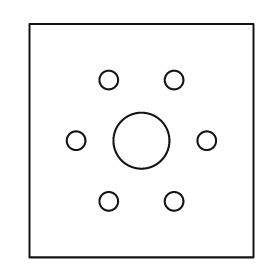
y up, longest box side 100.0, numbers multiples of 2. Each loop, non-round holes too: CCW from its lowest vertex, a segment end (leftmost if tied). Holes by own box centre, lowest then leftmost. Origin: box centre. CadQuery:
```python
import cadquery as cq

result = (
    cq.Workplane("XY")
    .moveTo(-48.0, -50.0)
    .lineTo(48.0, -50.0)
    .lineTo(48.0, 50.0)
    .lineTo(-48.0, 50.0)
    .close()
    .moveTo(-14.0, -26.0)
    .circle(4.0)
    .moveTo(14.0, -26.0)
    .circle(4.0)
    .moveTo(-28.0, 0.0)
    .circle(4.0)
    .moveTo(0.0, 0.0)
    .circle(12.0)
    .moveTo(28.0, 0.0)
    .circle(4.0)
    .moveTo(-14.0, 26.0)
    .circle(4.0)
    .moveTo(14.0, 26.0)
    .circle(4.0)
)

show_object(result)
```